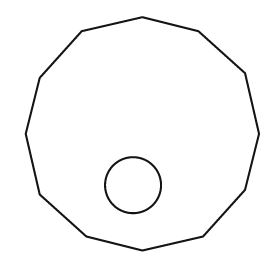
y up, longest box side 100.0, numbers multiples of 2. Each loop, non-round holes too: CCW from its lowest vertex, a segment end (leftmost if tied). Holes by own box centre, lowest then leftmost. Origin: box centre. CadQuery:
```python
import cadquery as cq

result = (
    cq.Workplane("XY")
    .moveTo(0.0, -50.0)
    .lineTo(26.0, -44.0)
    .lineTo(44.0, -24.0)
    .lineTo(50.0, 0.0)
    .lineTo(44.0, 26.0)
    .lineTo(24.0, 44.0)
    .lineTo(0.0, 50.0)
    .lineTo(-26.0, 44.0)
    .lineTo(-44.0, 24.0)
    .lineTo(-50.0, 0.0)
    .lineTo(-44.0, -26.0)
    .lineTo(-24.0, -44.0)
    .close()
    .moveTo(-4.0, -22.0)
    .circle(12.0)
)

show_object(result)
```